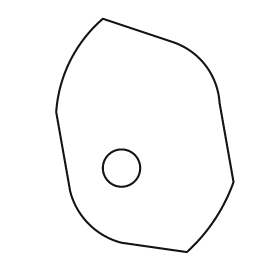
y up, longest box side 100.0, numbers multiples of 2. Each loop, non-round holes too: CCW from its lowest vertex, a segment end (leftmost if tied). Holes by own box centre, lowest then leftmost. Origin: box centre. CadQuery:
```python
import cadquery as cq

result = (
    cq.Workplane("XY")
    .moveTo(18.0, -50.0)
    .threePointArc((30.0, -36.0), (38.0, -20.0))
    .lineTo(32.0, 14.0)
    .threePointArc((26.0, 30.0), (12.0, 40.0))
    .lineTo(-18.0, 50.0)
    .threePointArc((-32.0, 32.0), (-38.0, 10.0))
    .lineTo(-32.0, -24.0)
    .threePointArc((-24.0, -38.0), (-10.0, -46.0))
    .close()
    .moveTo(-10.0, -14.0)
    .circle(8.0)
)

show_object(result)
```